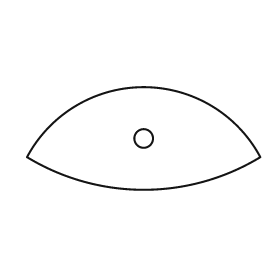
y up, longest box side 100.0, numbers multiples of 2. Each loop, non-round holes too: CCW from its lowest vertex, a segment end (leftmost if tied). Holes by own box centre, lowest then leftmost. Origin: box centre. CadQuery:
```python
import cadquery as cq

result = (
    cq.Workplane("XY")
    .moveTo(-50.0, -8.0)
    .threePointArc((0.0, -22.0), (50.0, -8.0))
    .threePointArc((0.0, 22.0), (-50.0, -8.0))
    .close()
    .moveTo(0.0, 0.0)
    .circle(4.0)
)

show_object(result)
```